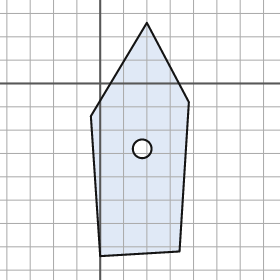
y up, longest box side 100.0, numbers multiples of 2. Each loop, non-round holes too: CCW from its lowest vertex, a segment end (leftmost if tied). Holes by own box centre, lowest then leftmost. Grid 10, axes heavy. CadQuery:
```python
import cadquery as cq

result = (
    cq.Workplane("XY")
    .moveTo(0.0, -74.0)
    .lineTo(34.0, -72.0)
    .lineTo(38.0, -8.0)
    .lineTo(20.0, 26.0)
    .lineTo(-4.0, -14.0)
    .close()
    .moveTo(18.0, -28.0)
    .circle(4.0)
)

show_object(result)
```